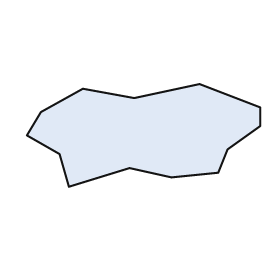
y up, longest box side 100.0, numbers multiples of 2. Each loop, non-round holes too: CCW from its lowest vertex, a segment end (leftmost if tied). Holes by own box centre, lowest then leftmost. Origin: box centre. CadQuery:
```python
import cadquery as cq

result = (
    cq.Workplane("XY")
    .moveTo(-32.0, -22.0)
    .lineTo(-6.0, -14.0)
    .lineTo(12.0, -18.0)
    .lineTo(32.0, -16.0)
    .lineTo(36.0, -6.0)
    .lineTo(50.0, 4.0)
    .lineTo(50.0, 12.0)
    .lineTo(24.0, 22.0)
    .lineTo(-4.0, 16.0)
    .lineTo(-26.0, 20.0)
    .lineTo(-44.0, 10.0)
    .lineTo(-50.0, 0.0)
    .lineTo(-36.0, -8.0)
    .close()
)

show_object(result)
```